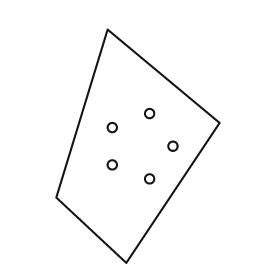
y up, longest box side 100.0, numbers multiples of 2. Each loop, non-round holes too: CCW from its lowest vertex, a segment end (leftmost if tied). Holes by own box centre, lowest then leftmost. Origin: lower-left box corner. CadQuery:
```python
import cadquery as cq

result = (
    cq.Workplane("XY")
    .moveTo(30.0, 0.0)
    .lineTo(70.0, 60.0)
    .lineTo(22.0, 100.0)
    .lineTo(0.0, 28.0)
    .close()
    .moveTo(40.0, 36.0)
    .circle(2.0)
    .moveTo(24.0, 42.0)
    .circle(2.0)
    .moveTo(50.0, 50.0)
    .circle(2.0)
    .moveTo(24.0, 58.0)
    .circle(2.0)
    .moveTo(40.0, 64.0)
    .circle(2.0)
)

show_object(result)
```